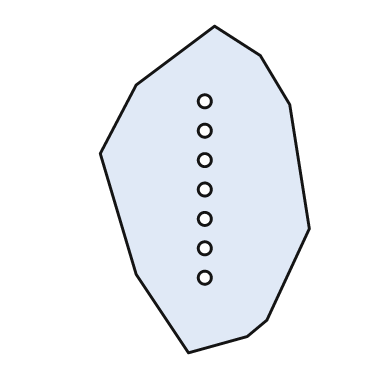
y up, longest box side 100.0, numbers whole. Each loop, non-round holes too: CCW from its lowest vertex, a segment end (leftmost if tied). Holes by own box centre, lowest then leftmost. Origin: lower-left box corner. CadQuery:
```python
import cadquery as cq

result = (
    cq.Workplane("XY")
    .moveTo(27.0, 0.0)
    .lineTo(45.0, 5.0)
    .lineTo(51.0, 10.0)
    .lineTo(64.0, 38.0)
    .lineTo(58.0, 76.0)
    .lineTo(49.0, 91.0)
    .lineTo(35.0, 100.0)
    .lineTo(11.0, 82.0)
    .lineTo(0.0, 61.0)
    .lineTo(11.0, 24.0)
    .close()
    .moveTo(32.0, 23.0)
    .circle(2.0)
    .moveTo(32.0, 32.0)
    .circle(2.0)
    .moveTo(32.0, 41.0)
    .circle(2.0)
    .moveTo(32.0, 50.0)
    .circle(2.0)
    .moveTo(32.0, 59.0)
    .circle(2.0)
    .moveTo(32.0, 68.0)
    .circle(2.0)
    .moveTo(32.0, 77.0)
    .circle(2.0)
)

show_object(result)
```